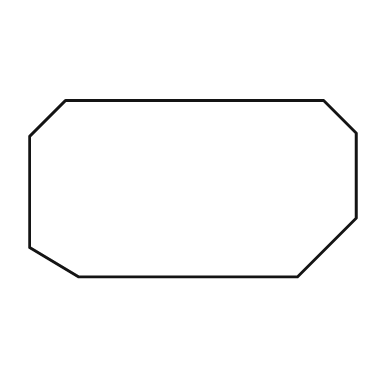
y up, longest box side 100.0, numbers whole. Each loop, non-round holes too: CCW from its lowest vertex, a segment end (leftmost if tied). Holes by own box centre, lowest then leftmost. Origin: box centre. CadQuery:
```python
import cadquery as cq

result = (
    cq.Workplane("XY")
    .moveTo(-35.0, -27.0)
    .lineTo(32.0, -27.0)
    .lineTo(50.0, -9.0)
    .lineTo(50.0, 17.0)
    .lineTo(40.0, 27.0)
    .lineTo(-39.0, 27.0)
    .lineTo(-50.0, 16.0)
    .lineTo(-50.0, -18.0)
    .close()
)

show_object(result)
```